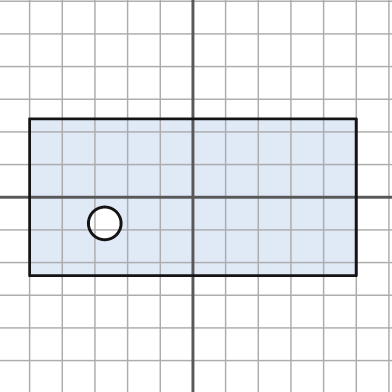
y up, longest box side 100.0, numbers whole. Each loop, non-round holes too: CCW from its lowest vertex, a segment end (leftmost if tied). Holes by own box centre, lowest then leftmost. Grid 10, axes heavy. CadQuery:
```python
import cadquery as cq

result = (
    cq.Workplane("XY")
    .moveTo(-50.0, -24.0)
    .lineTo(50.0, -24.0)
    .lineTo(50.0, 24.0)
    .lineTo(-50.0, 24.0)
    .close()
    .moveTo(-27.0, -8.0)
    .circle(5.0)
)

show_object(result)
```